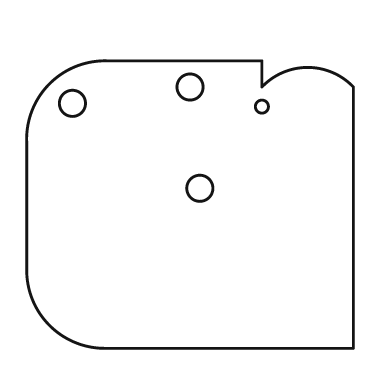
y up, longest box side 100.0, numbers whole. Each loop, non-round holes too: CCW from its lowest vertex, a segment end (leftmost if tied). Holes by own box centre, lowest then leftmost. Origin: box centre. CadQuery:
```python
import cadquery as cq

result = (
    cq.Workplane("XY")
    .moveTo(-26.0, -44.0)
    .lineTo(50.0, -44.0)
    .lineTo(50.0, 36.0)
    .threePointArc((36.0, 42.0), (22.0, 36.0))
    .lineTo(22.0, 44.0)
    .lineTo(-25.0, 44.0)
    .threePointArc((-43.0, 37.0), (-50.0, 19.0))
    .lineTo(-50.0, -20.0)
    .threePointArc((-43.0, -37.0), (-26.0, -44.0))
    .close()
    .moveTo(3.0, 5.0)
    .circle(4.0)
    .moveTo(22.0, 30.0)
    .circle(2.0)
    .moveTo(-36.0, 31.0)
    .circle(4.0)
    .moveTo(0.0, 36.0)
    .circle(4.0)
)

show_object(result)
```